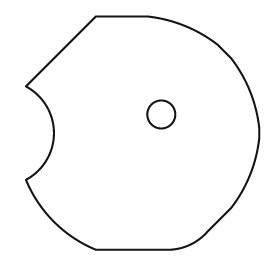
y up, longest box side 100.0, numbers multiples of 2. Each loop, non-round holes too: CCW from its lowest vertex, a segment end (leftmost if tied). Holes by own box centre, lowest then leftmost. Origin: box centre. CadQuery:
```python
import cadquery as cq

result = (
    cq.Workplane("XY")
    .moveTo(-20.0, -50.0)
    .lineTo(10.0, -50.0)
    .threePointArc((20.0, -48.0), (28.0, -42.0))
    .lineTo(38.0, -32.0)
    .threePointArc((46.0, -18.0), (50.0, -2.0))
    .lineTo(50.0, 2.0)
    .threePointArc((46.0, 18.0), (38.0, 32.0))
    .lineTo(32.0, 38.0)
    .threePointArc((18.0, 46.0), (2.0, 50.0))
    .lineTo(-20.0, 50.0)
    .lineTo(-50.0, 20.0)
    .threePointArc((-38.0, 0.0), (-50.0, -20.0))
    .threePointArc((-38.0, -38.0), (-20.0, -50.0))
    .close()
    .moveTo(8.0, 8.0)
    .circle(6.0)
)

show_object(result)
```